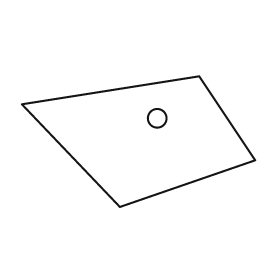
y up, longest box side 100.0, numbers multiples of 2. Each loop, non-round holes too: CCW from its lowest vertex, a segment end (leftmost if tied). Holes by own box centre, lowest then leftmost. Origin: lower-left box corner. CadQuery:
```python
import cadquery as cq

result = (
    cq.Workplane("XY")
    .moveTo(42.0, 0.0)
    .lineTo(100.0, 20.0)
    .lineTo(76.0, 56.0)
    .lineTo(0.0, 44.0)
    .close()
    .moveTo(58.0, 38.0)
    .circle(4.0)
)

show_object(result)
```